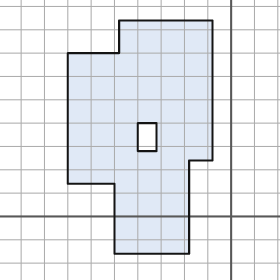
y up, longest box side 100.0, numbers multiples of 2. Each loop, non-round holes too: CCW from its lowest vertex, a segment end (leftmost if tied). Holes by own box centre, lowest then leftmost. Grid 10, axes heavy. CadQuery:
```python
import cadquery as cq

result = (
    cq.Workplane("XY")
    .moveTo(-50.0, -16.0)
    .lineTo(-18.0, -16.0)
    .lineTo(-18.0, 24.0)
    .lineTo(-8.0, 24.0)
    .lineTo(-8.0, 84.0)
    .lineTo(-48.0, 84.0)
    .lineTo(-48.0, 70.0)
    .lineTo(-70.0, 70.0)
    .lineTo(-70.0, 14.0)
    .lineTo(-50.0, 14.0)
    .close()
    .moveTo(-40.0, 28.0)
    .lineTo(-32.0, 28.0)
    .lineTo(-32.0, 40.0)
    .lineTo(-40.0, 40.0)
    .close()
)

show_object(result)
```